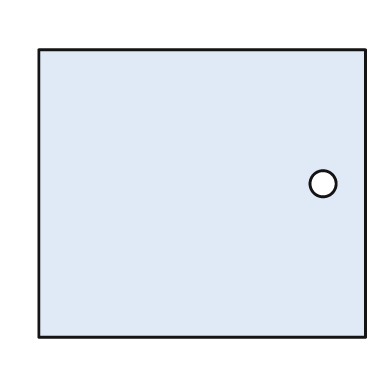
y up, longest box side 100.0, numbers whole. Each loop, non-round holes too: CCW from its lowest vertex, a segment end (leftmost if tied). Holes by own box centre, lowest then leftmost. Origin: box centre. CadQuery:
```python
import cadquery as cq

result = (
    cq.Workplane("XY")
    .moveTo(-50.0, -44.0)
    .lineTo(50.0, -44.0)
    .lineTo(50.0, 44.0)
    .lineTo(-50.0, 44.0)
    .close()
    .moveTo(37.0, 3.0)
    .circle(4.0)
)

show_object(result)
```